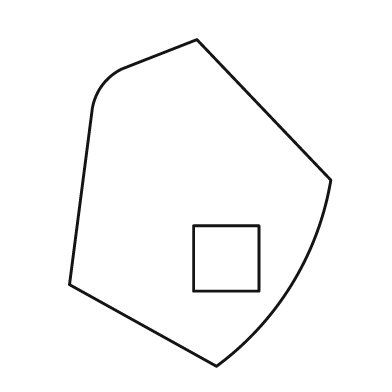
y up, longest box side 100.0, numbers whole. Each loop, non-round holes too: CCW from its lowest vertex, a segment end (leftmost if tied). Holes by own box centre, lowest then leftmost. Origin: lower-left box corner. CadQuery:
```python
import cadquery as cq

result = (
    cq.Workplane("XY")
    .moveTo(45.0, 0.0)
    .threePointArc((68.0, 25.0), (80.0, 57.0))
    .lineTo(39.0, 100.0)
    .lineTo(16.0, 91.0)
    .threePointArc((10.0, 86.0), (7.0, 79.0))
    .lineTo(0.0, 25.0)
    .close()
    .moveTo(38.0, 23.0)
    .lineTo(58.0, 23.0)
    .lineTo(58.0, 43.0)
    .lineTo(38.0, 43.0)
    .close()
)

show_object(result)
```